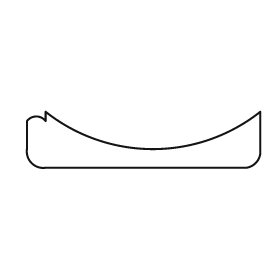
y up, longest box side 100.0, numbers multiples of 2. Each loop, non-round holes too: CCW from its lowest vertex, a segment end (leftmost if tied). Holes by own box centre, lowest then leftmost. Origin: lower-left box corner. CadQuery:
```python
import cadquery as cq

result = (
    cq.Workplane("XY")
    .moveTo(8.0, 0.0)
    .lineTo(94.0, 0.0)
    .threePointArc((98.0, 2.0), (100.0, 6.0))
    .lineTo(100.0, 24.0)
    .threePointArc((54.0, 8.0), (8.0, 24.0))
    .lineTo(8.0, 20.0)
    .threePointArc((4.0, 22.0), (0.0, 20.0))
    .lineTo(0.0, 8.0)
    .threePointArc((2.0, 2.0), (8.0, 0.0))
    .close()
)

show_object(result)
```